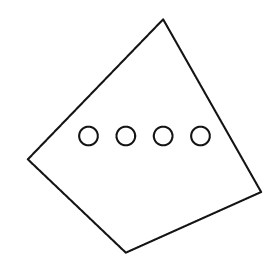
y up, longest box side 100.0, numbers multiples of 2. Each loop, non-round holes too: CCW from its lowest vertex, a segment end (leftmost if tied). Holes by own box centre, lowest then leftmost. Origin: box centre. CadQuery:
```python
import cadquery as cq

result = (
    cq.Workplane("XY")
    .moveTo(-8.0, -50.0)
    .lineTo(50.0, -24.0)
    .lineTo(8.0, 50.0)
    .lineTo(-50.0, -10.0)
    .close()
    .moveTo(-24.0, 0.0)
    .circle(4.0)
    .moveTo(-8.0, 0.0)
    .circle(4.0)
    .moveTo(8.0, 0.0)
    .circle(4.0)
    .moveTo(24.0, 0.0)
    .circle(4.0)
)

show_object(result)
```